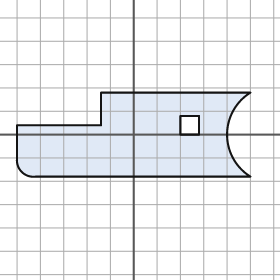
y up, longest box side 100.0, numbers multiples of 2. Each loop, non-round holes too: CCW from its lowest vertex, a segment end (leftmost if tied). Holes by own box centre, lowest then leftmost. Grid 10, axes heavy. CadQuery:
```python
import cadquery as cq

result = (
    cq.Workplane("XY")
    .moveTo(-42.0, -18.0)
    .lineTo(50.0, -18.0)
    .threePointArc((40.0, 0.0), (50.0, 18.0))
    .lineTo(-14.0, 18.0)
    .lineTo(-14.0, 4.0)
    .lineTo(-50.0, 4.0)
    .lineTo(-50.0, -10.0)
    .threePointArc((-48.0, -16.0), (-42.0, -18.0))
    .close()
    .moveTo(20.0, 0.0)
    .lineTo(28.0, 0.0)
    .lineTo(28.0, 8.0)
    .lineTo(20.0, 8.0)
    .close()
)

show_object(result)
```